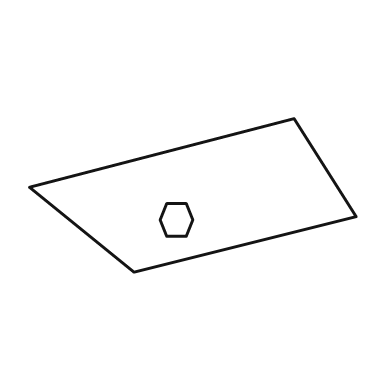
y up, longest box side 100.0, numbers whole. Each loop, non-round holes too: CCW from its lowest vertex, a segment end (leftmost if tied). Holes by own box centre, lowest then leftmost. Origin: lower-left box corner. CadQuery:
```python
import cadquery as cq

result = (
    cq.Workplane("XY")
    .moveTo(32.0, 0.0)
    .lineTo(100.0, 17.0)
    .lineTo(81.0, 47.0)
    .lineTo(0.0, 26.0)
    .close()
    .moveTo(42.0, 11.0)
    .lineTo(48.0, 11.0)
    .lineTo(50.0, 16.0)
    .lineTo(48.0, 21.0)
    .lineTo(42.0, 21.0)
    .lineTo(40.0, 16.0)
    .close()
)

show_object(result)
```